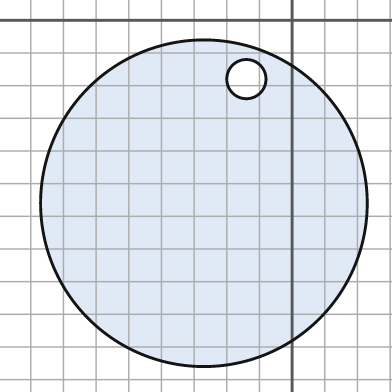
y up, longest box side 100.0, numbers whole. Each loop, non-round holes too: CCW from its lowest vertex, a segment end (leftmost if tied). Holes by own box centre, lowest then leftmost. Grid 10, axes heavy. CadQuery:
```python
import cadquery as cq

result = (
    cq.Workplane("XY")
    .moveTo(-27.0, -56.0)
    .circle(50.0)
    .moveTo(-14.0, -18.0)
    .circle(6.0)
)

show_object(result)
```